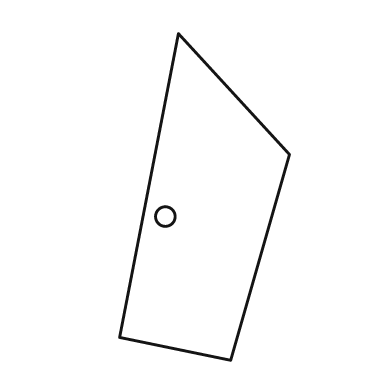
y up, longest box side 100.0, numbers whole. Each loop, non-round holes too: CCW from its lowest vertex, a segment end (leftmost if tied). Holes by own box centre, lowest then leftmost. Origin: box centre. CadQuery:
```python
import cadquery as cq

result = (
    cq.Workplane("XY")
    .moveTo(8.0, -50.0)
    .lineTo(26.0, 13.0)
    .lineTo(-8.0, 50.0)
    .lineTo(-26.0, -43.0)
    .close()
    .moveTo(-12.0, -6.0)
    .circle(3.0)
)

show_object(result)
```